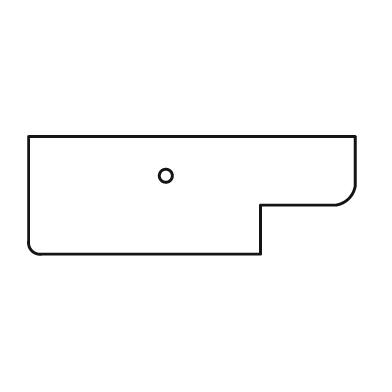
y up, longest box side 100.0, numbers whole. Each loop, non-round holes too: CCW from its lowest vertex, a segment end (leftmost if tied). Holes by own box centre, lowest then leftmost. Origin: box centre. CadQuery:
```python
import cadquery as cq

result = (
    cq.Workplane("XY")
    .moveTo(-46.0, -18.0)
    .lineTo(21.0, -18.0)
    .lineTo(21.0, -3.0)
    .lineTo(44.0, -3.0)
    .threePointArc((48.0, -1.0), (50.0, 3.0))
    .lineTo(50.0, 18.0)
    .lineTo(-50.0, 18.0)
    .lineTo(-50.0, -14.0)
    .threePointArc((-49.0, -17.0), (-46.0, -18.0))
    .close()
    .moveTo(-8.0, 6.0)
    .circle(2.0)
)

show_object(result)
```